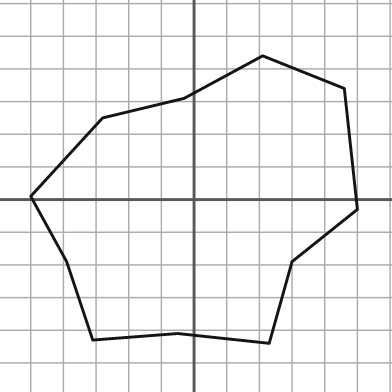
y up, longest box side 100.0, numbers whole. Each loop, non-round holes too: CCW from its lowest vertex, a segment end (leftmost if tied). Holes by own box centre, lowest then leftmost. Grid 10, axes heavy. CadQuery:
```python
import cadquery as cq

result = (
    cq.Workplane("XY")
    .moveTo(23.0, -44.0)
    .lineTo(30.0, -19.0)
    .lineTo(50.0, -3.0)
    .lineTo(46.0, 34.0)
    .lineTo(21.0, 44.0)
    .lineTo(-3.0, 31.0)
    .lineTo(-28.0, 25.0)
    .lineTo(-50.0, 1.0)
    .lineTo(-39.0, -19.0)
    .lineTo(-31.0, -43.0)
    .lineTo(-5.0, -41.0)
    .close()
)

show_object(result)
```